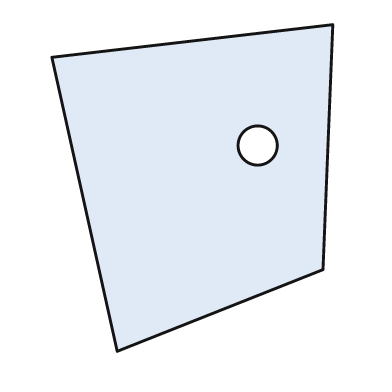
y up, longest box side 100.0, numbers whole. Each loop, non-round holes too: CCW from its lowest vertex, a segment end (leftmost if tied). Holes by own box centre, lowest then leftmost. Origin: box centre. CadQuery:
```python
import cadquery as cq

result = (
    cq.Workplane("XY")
    .moveTo(-23.0, -50.0)
    .lineTo(40.0, -25.0)
    .lineTo(43.0, 50.0)
    .lineTo(-43.0, 40.0)
    .close()
    .moveTo(20.0, 13.0)
    .circle(6.0)
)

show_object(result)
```